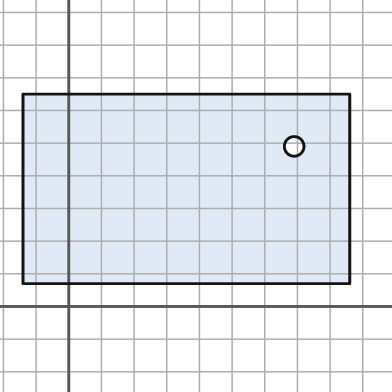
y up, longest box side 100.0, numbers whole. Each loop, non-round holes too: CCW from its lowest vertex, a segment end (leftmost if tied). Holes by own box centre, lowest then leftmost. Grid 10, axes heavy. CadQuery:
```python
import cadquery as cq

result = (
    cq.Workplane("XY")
    .moveTo(-14.0, 7.0)
    .lineTo(86.0, 7.0)
    .lineTo(86.0, 65.0)
    .lineTo(-14.0, 65.0)
    .close()
    .moveTo(69.0, 49.0)
    .circle(3.0)
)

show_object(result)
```